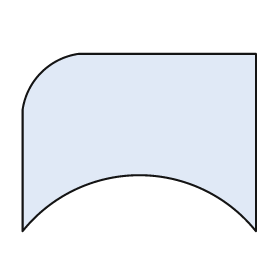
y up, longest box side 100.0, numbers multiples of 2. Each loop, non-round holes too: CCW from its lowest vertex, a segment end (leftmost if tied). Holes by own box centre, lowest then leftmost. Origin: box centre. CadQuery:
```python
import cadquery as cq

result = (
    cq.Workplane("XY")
    .moveTo(-50.0, -38.0)
    .threePointArc((0.0, -14.0), (50.0, -38.0))
    .lineTo(50.0, 38.0)
    .lineTo(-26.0, 38.0)
    .threePointArc((-42.0, 30.0), (-50.0, 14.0))
    .close()
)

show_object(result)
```